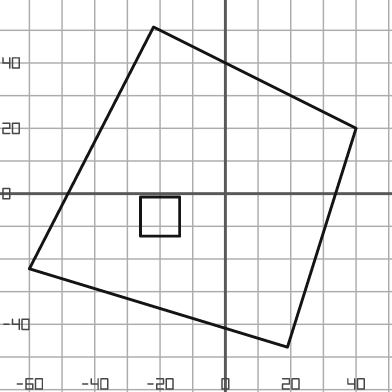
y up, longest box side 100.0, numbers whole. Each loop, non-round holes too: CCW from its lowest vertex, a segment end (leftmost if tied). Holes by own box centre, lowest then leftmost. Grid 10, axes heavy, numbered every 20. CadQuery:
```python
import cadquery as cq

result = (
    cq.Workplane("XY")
    .moveTo(19.0, -47.0)
    .lineTo(40.0, 20.0)
    .lineTo(-22.0, 51.0)
    .lineTo(-60.0, -23.0)
    .close()
    .moveTo(-26.0, -13.0)
    .lineTo(-14.0, -13.0)
    .lineTo(-14.0, -1.0)
    .lineTo(-26.0, -1.0)
    .close()
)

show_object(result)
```